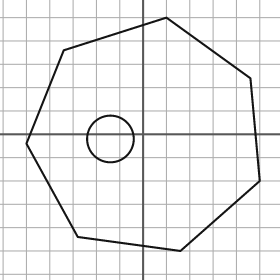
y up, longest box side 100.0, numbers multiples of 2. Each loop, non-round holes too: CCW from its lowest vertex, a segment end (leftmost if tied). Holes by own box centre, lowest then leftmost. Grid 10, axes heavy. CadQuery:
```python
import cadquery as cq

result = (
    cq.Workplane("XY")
    .moveTo(16.0, -50.0)
    .lineTo(50.0, -20.0)
    .lineTo(46.0, 24.0)
    .lineTo(10.0, 50.0)
    .lineTo(-34.0, 36.0)
    .lineTo(-50.0, -4.0)
    .lineTo(-28.0, -44.0)
    .close()
    .moveTo(-14.0, -2.0)
    .circle(10.0)
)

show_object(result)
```